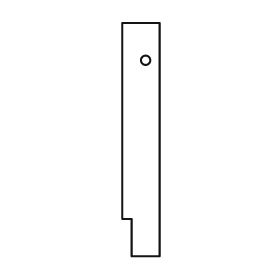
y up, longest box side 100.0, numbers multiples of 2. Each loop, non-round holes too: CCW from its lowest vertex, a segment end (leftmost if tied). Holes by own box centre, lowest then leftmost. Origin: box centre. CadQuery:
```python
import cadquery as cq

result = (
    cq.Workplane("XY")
    .moveTo(-4.0, -50.0)
    .lineTo(8.0, -50.0)
    .lineTo(8.0, 50.0)
    .lineTo(-8.0, 50.0)
    .lineTo(-8.0, -34.0)
    .lineTo(-4.0, -34.0)
    .close()
    .moveTo(2.0, 34.0)
    .circle(2.0)
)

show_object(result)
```